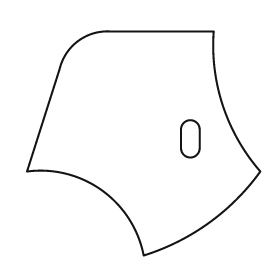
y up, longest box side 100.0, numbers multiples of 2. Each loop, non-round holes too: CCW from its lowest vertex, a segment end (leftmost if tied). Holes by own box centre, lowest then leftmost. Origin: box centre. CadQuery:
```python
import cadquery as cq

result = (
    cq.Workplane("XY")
    .moveTo(0.0, -48.0)
    .threePointArc((28.0, -34.0), (50.0, -12.0))
    .threePointArc((34.0, 16.0), (30.0, 48.0))
    .lineTo(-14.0, 48.0)
    .threePointArc((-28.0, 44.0), (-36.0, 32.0))
    .lineTo(-50.0, -12.0)
    .threePointArc((-18.0, -20.0), (0.0, -48.0))
    .close()
    .moveTo(16.0, -2.0)
    .threePointArc((20.0, -6.0), (24.0, -2.0))
    .lineTo(24.0, 6.0)
    .threePointArc((20.0, 10.0), (16.0, 6.0))
    .close()
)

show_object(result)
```